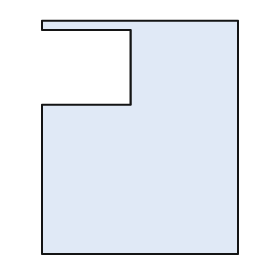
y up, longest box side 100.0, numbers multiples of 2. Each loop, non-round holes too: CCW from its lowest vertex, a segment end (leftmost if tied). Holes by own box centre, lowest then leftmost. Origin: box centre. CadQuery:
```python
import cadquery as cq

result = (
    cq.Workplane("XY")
    .moveTo(-42.0, -50.0)
    .lineTo(42.0, -50.0)
    .lineTo(42.0, 50.0)
    .lineTo(-42.0, 50.0)
    .lineTo(-42.0, 46.0)
    .lineTo(-4.0, 46.0)
    .lineTo(-4.0, 14.0)
    .lineTo(-42.0, 14.0)
    .close()
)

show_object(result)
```